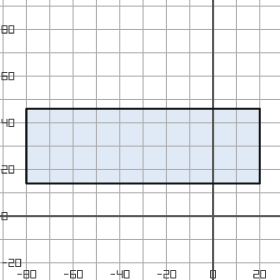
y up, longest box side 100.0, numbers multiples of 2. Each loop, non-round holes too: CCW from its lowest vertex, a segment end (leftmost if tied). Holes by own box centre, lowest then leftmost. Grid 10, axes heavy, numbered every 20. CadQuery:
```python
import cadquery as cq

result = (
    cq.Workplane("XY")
    .moveTo(-80.0, 14.0)
    .lineTo(20.0, 14.0)
    .lineTo(20.0, 46.0)
    .lineTo(-80.0, 46.0)
    .close()
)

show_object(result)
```